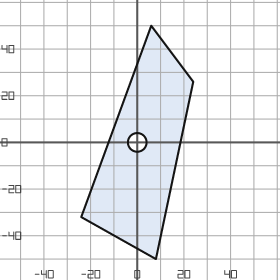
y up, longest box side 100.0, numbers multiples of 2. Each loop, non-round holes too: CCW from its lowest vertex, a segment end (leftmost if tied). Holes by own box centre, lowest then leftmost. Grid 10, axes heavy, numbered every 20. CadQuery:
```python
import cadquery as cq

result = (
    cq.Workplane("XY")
    .moveTo(8.0, -50.0)
    .lineTo(24.0, 26.0)
    .lineTo(6.0, 50.0)
    .lineTo(-24.0, -32.0)
    .close()
    .moveTo(0.0, 0.0)
    .circle(4.0)
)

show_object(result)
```